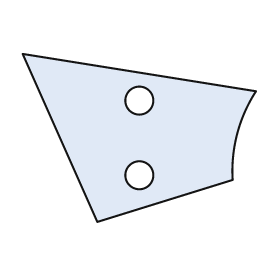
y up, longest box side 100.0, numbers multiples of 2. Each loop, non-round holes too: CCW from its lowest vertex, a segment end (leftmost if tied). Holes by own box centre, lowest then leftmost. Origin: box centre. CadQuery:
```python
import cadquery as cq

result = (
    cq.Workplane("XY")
    .moveTo(-18.0, -36.0)
    .lineTo(40.0, -18.0)
    .threePointArc((42.0, 2.0), (50.0, 20.0))
    .lineTo(-50.0, 36.0)
    .close()
    .moveTo(0.0, -16.0)
    .circle(6.0)
    .moveTo(0.0, 16.0)
    .circle(6.0)
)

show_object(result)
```